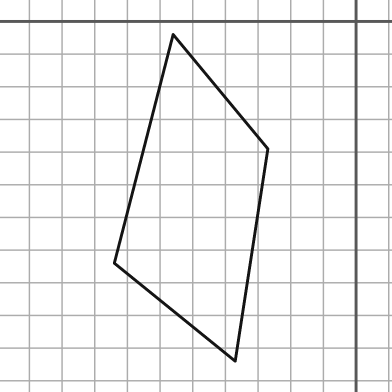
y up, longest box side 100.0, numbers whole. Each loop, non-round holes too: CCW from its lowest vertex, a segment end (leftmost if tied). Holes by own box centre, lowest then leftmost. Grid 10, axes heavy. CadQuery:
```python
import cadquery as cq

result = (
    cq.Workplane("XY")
    .moveTo(-37.0, -104.0)
    .lineTo(-27.0, -39.0)
    .lineTo(-56.0, -4.0)
    .lineTo(-74.0, -74.0)
    .close()
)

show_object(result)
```